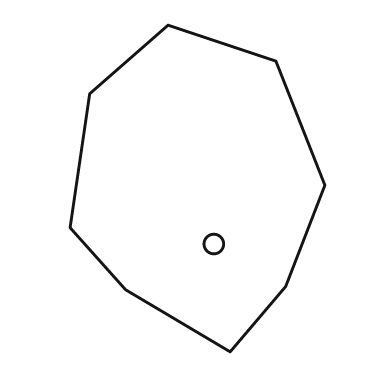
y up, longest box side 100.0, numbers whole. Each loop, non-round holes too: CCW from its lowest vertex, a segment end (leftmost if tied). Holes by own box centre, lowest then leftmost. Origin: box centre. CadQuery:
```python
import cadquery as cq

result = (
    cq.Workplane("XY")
    .moveTo(10.0, -50.0)
    .lineTo(27.0, -30.0)
    .lineTo(39.0, 1.0)
    .lineTo(24.0, 39.0)
    .lineTo(-9.0, 50.0)
    .lineTo(-33.0, 29.0)
    .lineTo(-39.0, -12.0)
    .lineTo(-22.0, -31.0)
    .close()
    .moveTo(5.0, -17.0)
    .circle(3.0)
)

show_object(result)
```